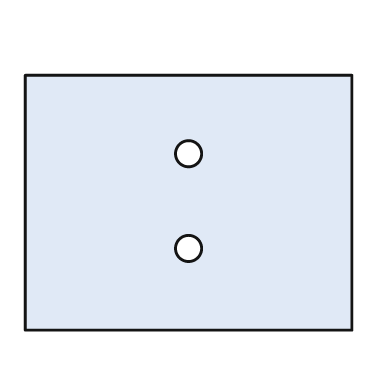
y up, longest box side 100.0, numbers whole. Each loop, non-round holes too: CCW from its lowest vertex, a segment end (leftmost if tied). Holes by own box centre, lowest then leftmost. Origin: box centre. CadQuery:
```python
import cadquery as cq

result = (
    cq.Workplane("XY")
    .moveTo(-50.0, -39.0)
    .lineTo(50.0, -39.0)
    .lineTo(50.0, 39.0)
    .lineTo(-50.0, 39.0)
    .close()
    .moveTo(0.0, -14.0)
    .circle(4.0)
    .moveTo(0.0, 15.0)
    .circle(4.0)
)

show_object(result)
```